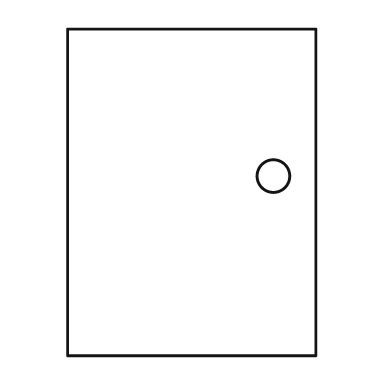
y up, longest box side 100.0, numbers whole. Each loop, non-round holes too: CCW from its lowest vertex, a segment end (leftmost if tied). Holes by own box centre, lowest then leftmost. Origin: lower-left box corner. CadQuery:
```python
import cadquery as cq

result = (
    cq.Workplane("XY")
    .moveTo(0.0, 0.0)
    .lineTo(76.0, 0.0)
    .lineTo(76.0, 100.0)
    .lineTo(0.0, 100.0)
    .close()
    .moveTo(63.0, 55.0)
    .circle(5.0)
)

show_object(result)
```